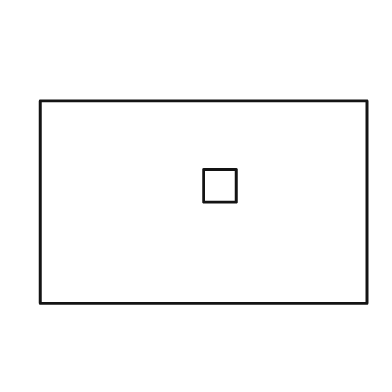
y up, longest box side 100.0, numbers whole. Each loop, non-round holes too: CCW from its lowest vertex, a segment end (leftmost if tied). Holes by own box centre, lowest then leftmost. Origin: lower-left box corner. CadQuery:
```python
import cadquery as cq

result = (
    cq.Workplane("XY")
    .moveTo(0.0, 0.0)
    .lineTo(100.0, 0.0)
    .lineTo(100.0, 62.0)
    .lineTo(0.0, 62.0)
    .close()
    .moveTo(50.0, 31.0)
    .lineTo(60.0, 31.0)
    .lineTo(60.0, 41.0)
    .lineTo(50.0, 41.0)
    .close()
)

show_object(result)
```